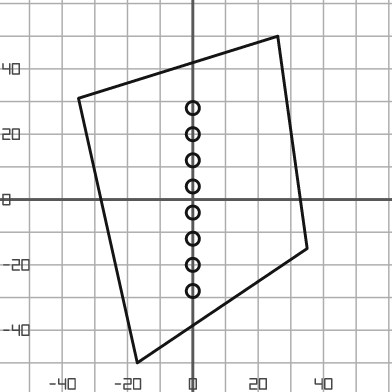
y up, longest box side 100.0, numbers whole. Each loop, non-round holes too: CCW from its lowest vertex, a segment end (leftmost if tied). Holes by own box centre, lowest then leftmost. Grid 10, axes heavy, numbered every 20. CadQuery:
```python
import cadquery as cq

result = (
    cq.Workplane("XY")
    .moveTo(-17.0, -50.0)
    .lineTo(35.0, -15.0)
    .lineTo(26.0, 50.0)
    .lineTo(-35.0, 31.0)
    .close()
    .moveTo(0.0, -28.0)
    .circle(2.0)
    .moveTo(0.0, -20.0)
    .circle(2.0)
    .moveTo(0.0, -12.0)
    .circle(2.0)
    .moveTo(0.0, -4.0)
    .circle(2.0)
    .moveTo(0.0, 4.0)
    .circle(2.0)
    .moveTo(0.0, 12.0)
    .circle(2.0)
    .moveTo(0.0, 20.0)
    .circle(2.0)
    .moveTo(0.0, 28.0)
    .circle(2.0)
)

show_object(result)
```